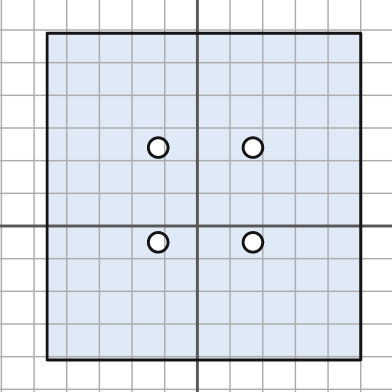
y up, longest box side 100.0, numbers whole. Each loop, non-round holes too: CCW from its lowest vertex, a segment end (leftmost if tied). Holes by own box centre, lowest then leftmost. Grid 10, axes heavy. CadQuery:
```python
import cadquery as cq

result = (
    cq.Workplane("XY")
    .moveTo(-46.0, -41.0)
    .lineTo(50.0, -41.0)
    .lineTo(50.0, 59.0)
    .lineTo(-46.0, 59.0)
    .close()
    .moveTo(-12.0, -5.0)
    .circle(3.0)
    .moveTo(17.0, -5.0)
    .circle(3.0)
    .moveTo(-12.0, 24.0)
    .circle(3.0)
    .moveTo(17.0, 24.0)
    .circle(3.0)
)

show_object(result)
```